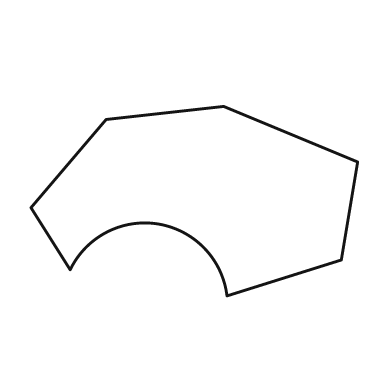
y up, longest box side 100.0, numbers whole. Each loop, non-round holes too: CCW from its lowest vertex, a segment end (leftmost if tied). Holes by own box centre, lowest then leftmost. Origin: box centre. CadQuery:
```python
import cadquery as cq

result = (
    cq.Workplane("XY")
    .moveTo(10.0, -29.0)
    .lineTo(45.0, -18.0)
    .lineTo(50.0, 12.0)
    .lineTo(9.0, 29.0)
    .lineTo(-27.0, 25.0)
    .lineTo(-50.0, -2.0)
    .lineTo(-38.0, -21.0)
    .threePointArc((-11.0, -7.0), (10.0, -29.0))
    .close()
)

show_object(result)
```